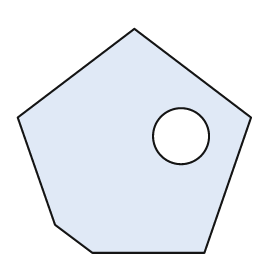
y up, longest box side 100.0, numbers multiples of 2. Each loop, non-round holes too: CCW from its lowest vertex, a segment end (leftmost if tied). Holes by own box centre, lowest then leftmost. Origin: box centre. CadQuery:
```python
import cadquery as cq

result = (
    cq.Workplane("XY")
    .moveTo(-18.0, -48.0)
    .lineTo(30.0, -48.0)
    .lineTo(50.0, 10.0)
    .lineTo(0.0, 48.0)
    .lineTo(-50.0, 10.0)
    .lineTo(-34.0, -36.0)
    .close()
    .moveTo(20.0, 2.0)
    .circle(12.0)
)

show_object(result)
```